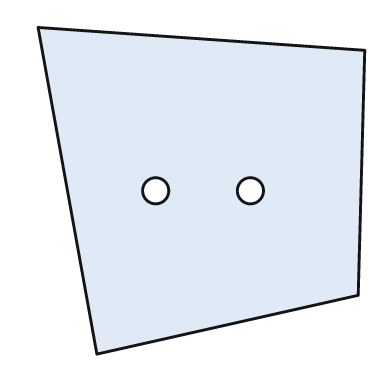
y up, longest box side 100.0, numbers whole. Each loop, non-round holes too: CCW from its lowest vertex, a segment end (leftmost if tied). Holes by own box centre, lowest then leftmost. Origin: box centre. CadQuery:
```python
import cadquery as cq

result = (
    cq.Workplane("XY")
    .moveTo(-32.0, -50.0)
    .lineTo(48.0, -32.0)
    .lineTo(50.0, 43.0)
    .lineTo(-50.0, 50.0)
    .close()
    .moveTo(-14.0, 0.0)
    .circle(4.0)
    .moveTo(15.0, 0.0)
    .circle(4.0)
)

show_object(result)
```